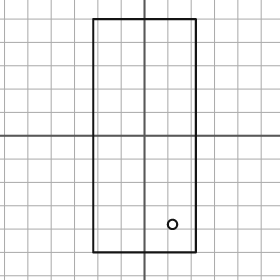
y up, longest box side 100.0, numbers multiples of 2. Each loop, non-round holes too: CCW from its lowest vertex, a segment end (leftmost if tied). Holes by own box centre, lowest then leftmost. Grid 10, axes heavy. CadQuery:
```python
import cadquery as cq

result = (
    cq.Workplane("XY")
    .moveTo(-22.0, -50.0)
    .lineTo(22.0, -50.0)
    .lineTo(22.0, 50.0)
    .lineTo(-22.0, 50.0)
    .close()
    .moveTo(12.0, -38.0)
    .circle(2.0)
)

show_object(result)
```